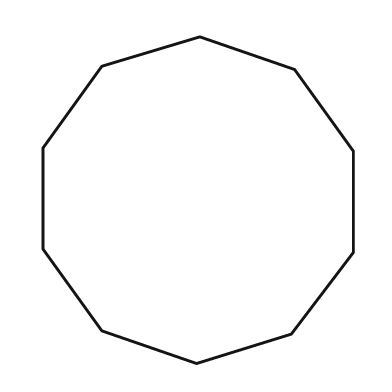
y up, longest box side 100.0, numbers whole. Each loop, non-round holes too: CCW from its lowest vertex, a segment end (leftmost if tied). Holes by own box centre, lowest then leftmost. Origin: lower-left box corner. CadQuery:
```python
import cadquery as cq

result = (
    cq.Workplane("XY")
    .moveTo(47.0, 0.0)
    .lineTo(76.0, 9.0)
    .lineTo(95.0, 34.0)
    .lineTo(95.0, 65.0)
    .lineTo(77.0, 90.0)
    .lineTo(48.0, 100.0)
    .lineTo(18.0, 91.0)
    .lineTo(0.0, 66.0)
    .lineTo(0.0, 35.0)
    .lineTo(18.0, 10.0)
    .close()
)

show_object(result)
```